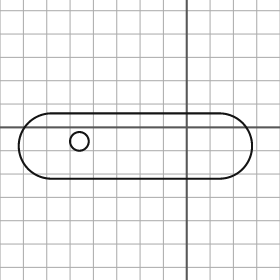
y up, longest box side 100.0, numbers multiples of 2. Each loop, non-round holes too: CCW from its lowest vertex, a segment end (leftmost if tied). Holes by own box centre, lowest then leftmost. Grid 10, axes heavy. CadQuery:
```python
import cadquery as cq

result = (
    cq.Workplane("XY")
    .moveTo(-58.0, -22.0)
    .lineTo(14.0, -22.0)
    .threePointArc((28.0, -8.0), (14.0, 6.0))
    .lineTo(-58.0, 6.0)
    .threePointArc((-72.0, -8.0), (-58.0, -22.0))
    .close()
    .moveTo(-46.0, -6.0)
    .circle(4.0)
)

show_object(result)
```